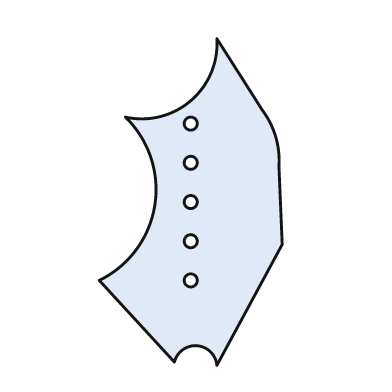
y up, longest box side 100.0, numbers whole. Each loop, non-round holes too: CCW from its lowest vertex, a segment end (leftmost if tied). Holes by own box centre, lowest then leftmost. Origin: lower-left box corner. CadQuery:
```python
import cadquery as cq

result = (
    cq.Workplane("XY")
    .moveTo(36.0, 0.0)
    .lineTo(56.0, 37.0)
    .lineTo(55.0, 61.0)
    .threePointArc((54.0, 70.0), (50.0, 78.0))
    .lineTo(36.0, 100.0)
    .threePointArc((28.0, 81.0), (8.0, 76.0))
    .threePointArc((17.0, 49.0), (0.0, 26.0))
    .lineTo(23.0, 1.0)
    .threePointArc((30.0, 6.0), (36.0, 0.0))
    .close()
    .moveTo(28.0, 26.0)
    .circle(2.0)
    .moveTo(28.0, 38.0)
    .circle(2.0)
    .moveTo(28.0, 50.0)
    .circle(2.0)
    .moveTo(28.0, 62.0)
    .circle(2.0)
    .moveTo(28.0, 74.0)
    .circle(2.0)
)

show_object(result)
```